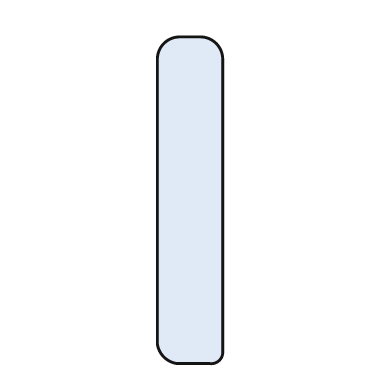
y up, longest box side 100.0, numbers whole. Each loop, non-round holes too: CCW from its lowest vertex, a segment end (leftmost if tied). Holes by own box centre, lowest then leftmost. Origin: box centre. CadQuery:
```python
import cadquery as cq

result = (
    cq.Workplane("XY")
    .moveTo(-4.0, -50.0)
    .lineTo(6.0, -50.0)
    .threePointArc((9.0, -49.0), (10.0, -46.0))
    .lineTo(10.0, 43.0)
    .threePointArc((8.0, 48.0), (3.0, 50.0))
    .lineTo(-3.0, 50.0)
    .threePointArc((-8.0, 48.0), (-10.0, 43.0))
    .lineTo(-10.0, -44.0)
    .threePointArc((-8.0, -48.0), (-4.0, -50.0))
    .close()
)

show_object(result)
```